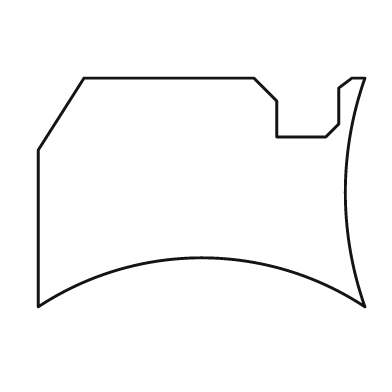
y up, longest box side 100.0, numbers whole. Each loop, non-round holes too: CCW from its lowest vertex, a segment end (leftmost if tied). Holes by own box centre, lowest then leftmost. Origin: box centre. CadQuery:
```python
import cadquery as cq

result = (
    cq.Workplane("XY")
    .moveTo(-50.0, -35.0)
    .threePointArc((0.0, -20.0), (50.0, -35.0))
    .threePointArc((44.0, 0.0), (50.0, 35.0))
    .lineTo(46.0, 35.0)
    .lineTo(42.0, 32.0)
    .lineTo(42.0, 21.0)
    .lineTo(38.0, 17.0)
    .lineTo(23.0, 17.0)
    .lineTo(23.0, 28.0)
    .lineTo(16.0, 35.0)
    .lineTo(-36.0, 35.0)
    .lineTo(-50.0, 13.0)
    .close()
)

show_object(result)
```